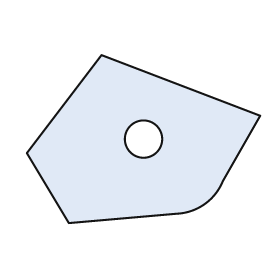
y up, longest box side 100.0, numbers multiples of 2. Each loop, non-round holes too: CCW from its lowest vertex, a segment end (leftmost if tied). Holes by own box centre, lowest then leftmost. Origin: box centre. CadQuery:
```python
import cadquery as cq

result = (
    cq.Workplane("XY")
    .moveTo(-32.0, -36.0)
    .lineTo(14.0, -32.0)
    .threePointArc((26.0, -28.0), (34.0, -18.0))
    .lineTo(50.0, 10.0)
    .lineTo(-18.0, 36.0)
    .lineTo(-50.0, -6.0)
    .close()
    .moveTo(0.0, 0.0)
    .circle(8.0)
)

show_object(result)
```